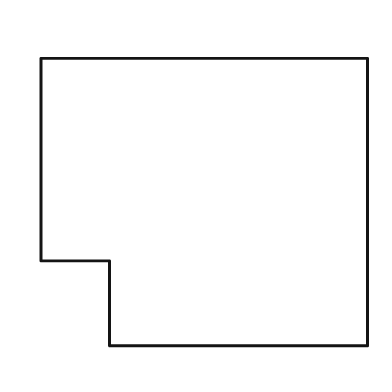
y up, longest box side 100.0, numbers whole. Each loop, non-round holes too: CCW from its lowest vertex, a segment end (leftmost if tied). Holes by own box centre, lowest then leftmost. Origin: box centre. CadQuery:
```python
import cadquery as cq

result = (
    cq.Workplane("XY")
    .moveTo(-29.0, -44.0)
    .lineTo(50.0, -44.0)
    .lineTo(50.0, 44.0)
    .lineTo(-50.0, 44.0)
    .lineTo(-50.0, -18.0)
    .lineTo(-29.0, -18.0)
    .close()
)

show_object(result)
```